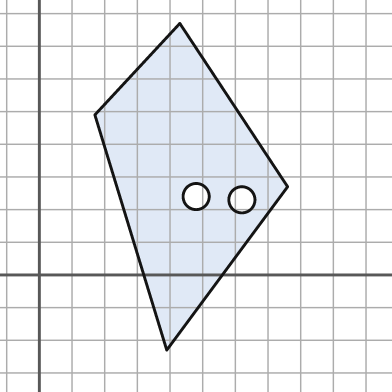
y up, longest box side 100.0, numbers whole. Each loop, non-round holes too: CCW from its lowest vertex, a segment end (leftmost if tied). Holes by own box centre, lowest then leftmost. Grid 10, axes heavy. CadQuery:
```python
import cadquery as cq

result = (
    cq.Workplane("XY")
    .moveTo(39.0, -23.0)
    .lineTo(76.0, 27.0)
    .lineTo(43.0, 77.0)
    .lineTo(17.0, 49.0)
    .close()
    .moveTo(62.0, 23.0)
    .circle(4.0)
    .moveTo(48.0, 24.0)
    .circle(4.0)
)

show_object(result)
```